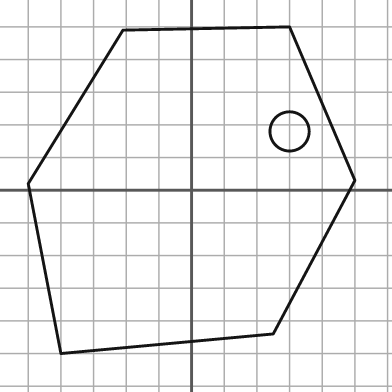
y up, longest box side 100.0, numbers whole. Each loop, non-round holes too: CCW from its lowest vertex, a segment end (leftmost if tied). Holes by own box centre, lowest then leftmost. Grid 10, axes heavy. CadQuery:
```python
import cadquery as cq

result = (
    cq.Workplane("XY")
    .moveTo(-40.0, -50.0)
    .lineTo(25.0, -44.0)
    .lineTo(50.0, 3.0)
    .lineTo(30.0, 50.0)
    .lineTo(-21.0, 49.0)
    .lineTo(-50.0, 2.0)
    .close()
    .moveTo(30.0, 18.0)
    .circle(6.0)
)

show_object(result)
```